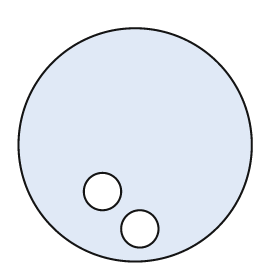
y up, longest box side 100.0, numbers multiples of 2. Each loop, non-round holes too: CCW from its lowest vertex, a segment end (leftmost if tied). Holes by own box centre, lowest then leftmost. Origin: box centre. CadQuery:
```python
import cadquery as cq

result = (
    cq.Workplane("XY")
    .moveTo(0.0, 0.0)
    .circle(50.0)
    .moveTo(2.0, -36.0)
    .circle(8.0)
    .moveTo(-14.0, -20.0)
    .circle(8.0)
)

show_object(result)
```